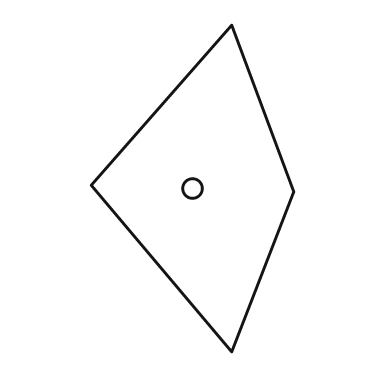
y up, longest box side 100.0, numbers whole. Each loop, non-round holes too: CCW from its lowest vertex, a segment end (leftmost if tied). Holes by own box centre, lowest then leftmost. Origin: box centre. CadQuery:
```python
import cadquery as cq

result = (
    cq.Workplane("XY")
    .moveTo(12.0, -50.0)
    .lineTo(31.0, -1.0)
    .lineTo(12.0, 50.0)
    .lineTo(-31.0, 1.0)
    .close()
    .moveTo(0.0, 0.0)
    .circle(3.0)
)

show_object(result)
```